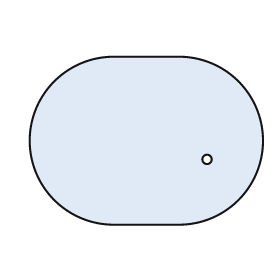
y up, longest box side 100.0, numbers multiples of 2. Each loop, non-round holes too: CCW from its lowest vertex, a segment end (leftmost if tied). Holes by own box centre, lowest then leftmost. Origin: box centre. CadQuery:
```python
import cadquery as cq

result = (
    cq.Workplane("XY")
    .moveTo(-14.0, -36.0)
    .lineTo(14.0, -36.0)
    .threePointArc((50.0, 0.0), (14.0, 36.0))
    .lineTo(-14.0, 36.0)
    .threePointArc((-50.0, 0.0), (-14.0, -36.0))
    .close()
    .moveTo(26.0, -8.0)
    .circle(2.0)
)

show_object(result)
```